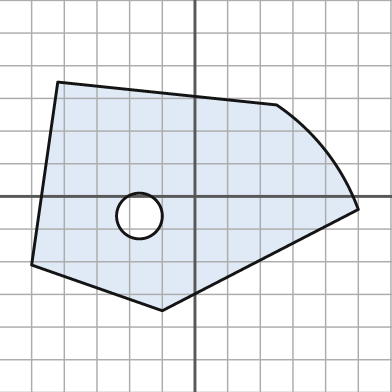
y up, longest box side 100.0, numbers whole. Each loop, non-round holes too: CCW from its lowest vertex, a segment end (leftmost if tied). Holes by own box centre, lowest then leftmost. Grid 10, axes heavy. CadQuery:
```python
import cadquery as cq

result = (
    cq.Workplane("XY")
    .moveTo(-10.0, -35.0)
    .lineTo(50.0, -4.0)
    .threePointArc((40.0, 14.0), (25.0, 28.0))
    .lineTo(-42.0, 35.0)
    .lineTo(-50.0, -21.0)
    .close()
    .moveTo(-17.0, -6.0)
    .circle(7.0)
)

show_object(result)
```